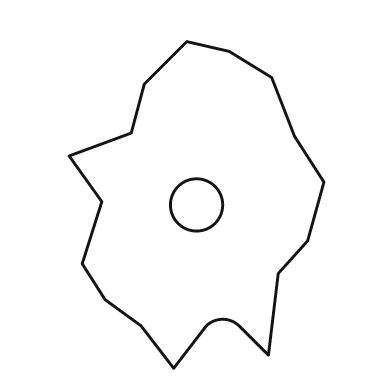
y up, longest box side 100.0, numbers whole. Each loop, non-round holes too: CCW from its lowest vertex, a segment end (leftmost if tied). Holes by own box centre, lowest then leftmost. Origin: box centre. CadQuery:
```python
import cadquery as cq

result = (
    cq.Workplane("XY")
    .moveTo(-7.0, -50.0)
    .lineTo(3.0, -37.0)
    .threePointArc((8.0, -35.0), (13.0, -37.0))
    .lineTo(22.0, -46.0)
    .lineTo(25.0, -21.0)
    .lineTo(34.0, -11.0)
    .lineTo(39.0, 7.0)
    .lineTo(30.0, 21.0)
    .lineTo(23.0, 39.0)
    .lineTo(10.0, 47.0)
    .lineTo(-3.0, 50.0)
    .lineTo(-16.0, 37.0)
    .lineTo(-20.0, 22.0)
    .lineTo(-39.0, 15.0)
    .lineTo(-29.0, 1.0)
    .lineTo(-35.0, -18.0)
    .lineTo(-28.0, -29.0)
    .lineTo(-17.0, -37.0)
    .close()
    .moveTo(0.0, 0.0)
    .circle(8.0)
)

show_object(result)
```